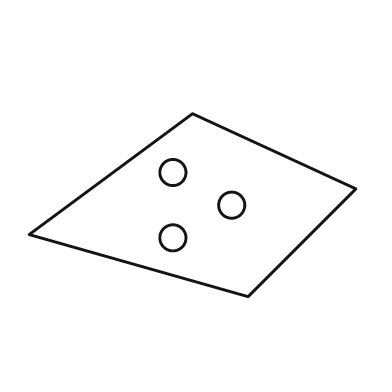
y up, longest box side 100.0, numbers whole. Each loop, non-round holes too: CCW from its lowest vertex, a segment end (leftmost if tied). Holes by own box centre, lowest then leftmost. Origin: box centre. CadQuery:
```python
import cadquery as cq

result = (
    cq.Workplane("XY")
    .moveTo(17.0, -28.0)
    .lineTo(50.0, 5.0)
    .lineTo(0.0, 28.0)
    .lineTo(-50.0, -9.0)
    .close()
    .moveTo(-6.0, -10.0)
    .circle(4.0)
    .moveTo(12.0, 0.0)
    .circle(4.0)
    .moveTo(-6.0, 10.0)
    .circle(4.0)
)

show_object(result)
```